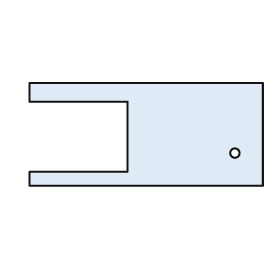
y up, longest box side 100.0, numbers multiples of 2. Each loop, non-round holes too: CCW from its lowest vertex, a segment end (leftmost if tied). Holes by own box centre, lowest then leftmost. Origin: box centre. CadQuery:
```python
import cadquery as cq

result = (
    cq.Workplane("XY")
    .moveTo(-50.0, -22.0)
    .lineTo(50.0, -22.0)
    .lineTo(50.0, 22.0)
    .lineTo(-50.0, 22.0)
    .lineTo(-50.0, 14.0)
    .lineTo(-8.0, 14.0)
    .lineTo(-8.0, -16.0)
    .lineTo(-50.0, -16.0)
    .close()
    .moveTo(38.0, -8.0)
    .circle(2.0)
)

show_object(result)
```